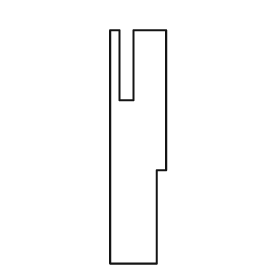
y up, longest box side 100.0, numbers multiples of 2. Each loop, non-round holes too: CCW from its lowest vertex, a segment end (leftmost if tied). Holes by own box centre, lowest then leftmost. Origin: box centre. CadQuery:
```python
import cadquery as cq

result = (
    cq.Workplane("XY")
    .moveTo(-12.0, -50.0)
    .lineTo(8.0, -50.0)
    .lineTo(8.0, -10.0)
    .lineTo(12.0, -10.0)
    .lineTo(12.0, 50.0)
    .lineTo(-2.0, 50.0)
    .lineTo(-2.0, 20.0)
    .lineTo(-8.0, 20.0)
    .lineTo(-8.0, 50.0)
    .lineTo(-12.0, 50.0)
    .close()
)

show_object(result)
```